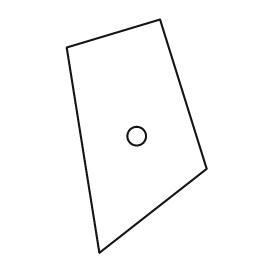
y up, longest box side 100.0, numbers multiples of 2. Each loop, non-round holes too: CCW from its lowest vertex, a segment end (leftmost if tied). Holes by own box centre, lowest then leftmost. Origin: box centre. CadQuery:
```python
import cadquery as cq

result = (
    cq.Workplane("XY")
    .moveTo(-16.0, -50.0)
    .lineTo(30.0, -14.0)
    .lineTo(10.0, 50.0)
    .lineTo(-30.0, 38.0)
    .close()
    .moveTo(0.0, 0.0)
    .circle(4.0)
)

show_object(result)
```